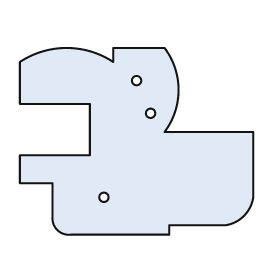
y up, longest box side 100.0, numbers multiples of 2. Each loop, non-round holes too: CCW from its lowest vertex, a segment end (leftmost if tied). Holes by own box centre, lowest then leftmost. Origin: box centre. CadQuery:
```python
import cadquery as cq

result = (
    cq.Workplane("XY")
    .moveTo(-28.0, -40.0)
    .lineTo(14.0, -40.0)
    .lineTo(14.0, -36.0)
    .lineTo(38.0, -36.0)
    .threePointArc((46.0, -32.0), (50.0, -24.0))
    .lineTo(50.0, 4.0)
    .lineTo(12.0, 4.0)
    .threePointArc((18.0, 22.0), (12.0, 40.0))
    .lineTo(-10.0, 40.0)
    .lineTo(-10.0, 34.0)
    .threePointArc((-30.0, 40.0), (-50.0, 34.0))
    .lineTo(-50.0, 16.0)
    .lineTo(-20.0, 16.0)
    .lineTo(-20.0, -6.0)
    .lineTo(-50.0, -6.0)
    .lineTo(-50.0, -18.0)
    .lineTo(-36.0, -18.0)
    .lineTo(-36.0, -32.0)
    .threePointArc((-34.0, -38.0), (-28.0, -40.0))
    .close()
    .moveTo(-14.0, -24.0)
    .circle(2.0)
    .moveTo(6.0, 12.0)
    .circle(2.0)
    .moveTo(0.0, 26.0)
    .circle(2.0)
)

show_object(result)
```